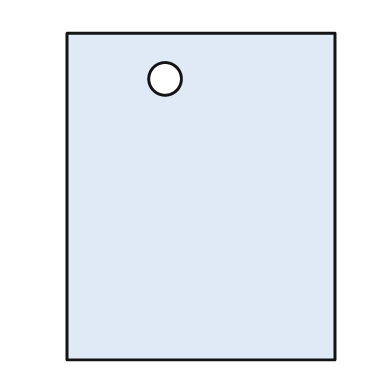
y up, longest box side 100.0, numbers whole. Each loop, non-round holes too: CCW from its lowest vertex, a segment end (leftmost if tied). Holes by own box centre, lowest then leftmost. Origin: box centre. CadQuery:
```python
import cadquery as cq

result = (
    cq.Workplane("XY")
    .moveTo(-41.0, -50.0)
    .lineTo(41.0, -50.0)
    .lineTo(41.0, 50.0)
    .lineTo(-41.0, 50.0)
    .close()
    .moveTo(-11.0, 36.0)
    .circle(5.0)
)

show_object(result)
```